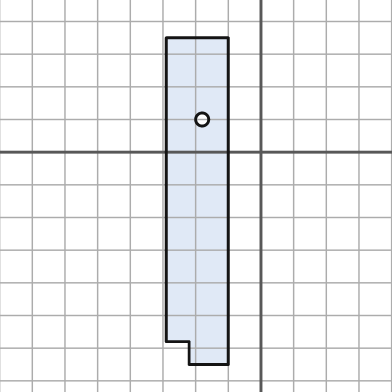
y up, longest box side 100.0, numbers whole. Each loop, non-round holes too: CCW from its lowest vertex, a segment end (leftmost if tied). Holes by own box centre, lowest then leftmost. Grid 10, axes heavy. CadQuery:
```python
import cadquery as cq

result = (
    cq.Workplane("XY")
    .moveTo(-22.0, -65.0)
    .lineTo(-10.0, -65.0)
    .lineTo(-10.0, 35.0)
    .lineTo(-29.0, 35.0)
    .lineTo(-29.0, -58.0)
    .lineTo(-22.0, -58.0)
    .close()
    .moveTo(-18.0, 10.0)
    .circle(2.0)
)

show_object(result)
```